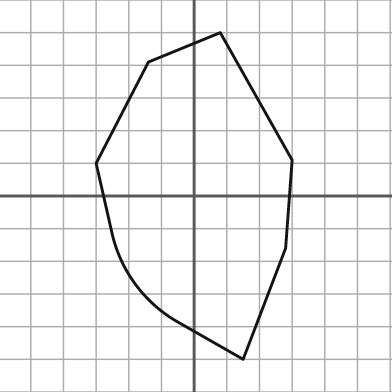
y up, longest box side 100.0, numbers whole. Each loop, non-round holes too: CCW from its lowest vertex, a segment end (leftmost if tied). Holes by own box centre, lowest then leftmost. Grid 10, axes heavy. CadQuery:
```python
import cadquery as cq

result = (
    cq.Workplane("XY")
    .moveTo(15.0, -50.0)
    .lineTo(28.0, -16.0)
    .lineTo(30.0, 11.0)
    .lineTo(8.0, 50.0)
    .lineTo(-14.0, 41.0)
    .lineTo(-30.0, 10.0)
    .lineTo(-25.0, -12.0)
    .threePointArc((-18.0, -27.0), (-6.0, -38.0))
    .close()
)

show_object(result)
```